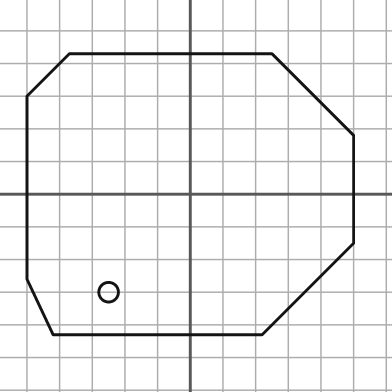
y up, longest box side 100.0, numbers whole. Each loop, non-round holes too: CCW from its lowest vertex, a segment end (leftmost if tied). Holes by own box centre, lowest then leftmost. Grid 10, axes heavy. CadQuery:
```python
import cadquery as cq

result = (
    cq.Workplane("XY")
    .moveTo(-42.0, -43.0)
    .lineTo(22.0, -43.0)
    .lineTo(50.0, -15.0)
    .lineTo(50.0, 18.0)
    .lineTo(25.0, 43.0)
    .lineTo(-37.0, 43.0)
    .lineTo(-50.0, 30.0)
    .lineTo(-50.0, -26.0)
    .close()
    .moveTo(-25.0, -30.0)
    .circle(3.0)
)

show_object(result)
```